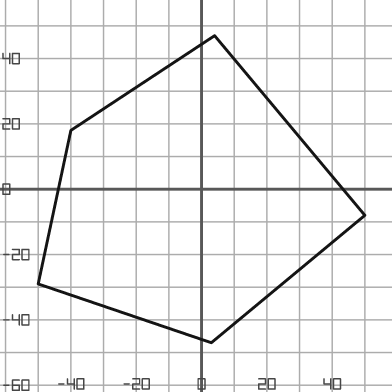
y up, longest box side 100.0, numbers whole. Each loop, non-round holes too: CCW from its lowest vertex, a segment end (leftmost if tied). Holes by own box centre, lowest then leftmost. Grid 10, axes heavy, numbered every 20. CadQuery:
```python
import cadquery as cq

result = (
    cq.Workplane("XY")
    .moveTo(3.0, -47.0)
    .lineTo(50.0, -8.0)
    .lineTo(4.0, 47.0)
    .lineTo(-40.0, 18.0)
    .lineTo(-50.0, -29.0)
    .close()
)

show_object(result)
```